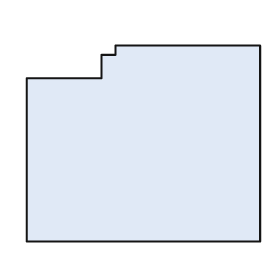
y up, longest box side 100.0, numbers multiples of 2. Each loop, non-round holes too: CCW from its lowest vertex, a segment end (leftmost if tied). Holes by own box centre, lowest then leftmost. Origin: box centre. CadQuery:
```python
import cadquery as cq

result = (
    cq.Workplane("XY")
    .moveTo(-50.0, -42.0)
    .lineTo(50.0, -42.0)
    .lineTo(50.0, 42.0)
    .lineTo(-12.0, 42.0)
    .lineTo(-12.0, 38.0)
    .lineTo(-18.0, 38.0)
    .lineTo(-18.0, 28.0)
    .lineTo(-50.0, 28.0)
    .close()
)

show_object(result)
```